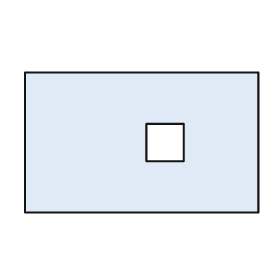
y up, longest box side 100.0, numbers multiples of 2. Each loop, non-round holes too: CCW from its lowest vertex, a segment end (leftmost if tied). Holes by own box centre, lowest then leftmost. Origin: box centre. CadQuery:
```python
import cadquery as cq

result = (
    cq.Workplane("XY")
    .moveTo(-50.0, -30.0)
    .lineTo(50.0, -30.0)
    .lineTo(50.0, 30.0)
    .lineTo(-50.0, 30.0)
    .close()
    .moveTo(2.0, -8.0)
    .lineTo(18.0, -8.0)
    .lineTo(18.0, 8.0)
    .lineTo(2.0, 8.0)
    .close()
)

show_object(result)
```